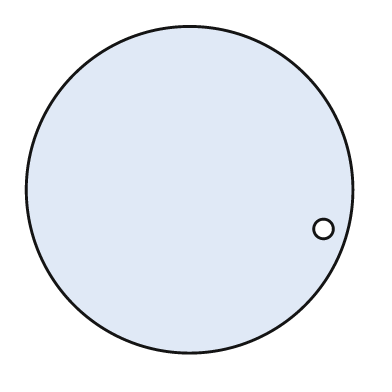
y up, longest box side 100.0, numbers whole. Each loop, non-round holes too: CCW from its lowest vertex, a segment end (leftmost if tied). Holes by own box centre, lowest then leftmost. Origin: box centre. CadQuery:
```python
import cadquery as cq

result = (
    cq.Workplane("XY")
    .moveTo(0.0, 0.0)
    .circle(50.0)
    .moveTo(41.0, -12.0)
    .circle(3.0)
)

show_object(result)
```